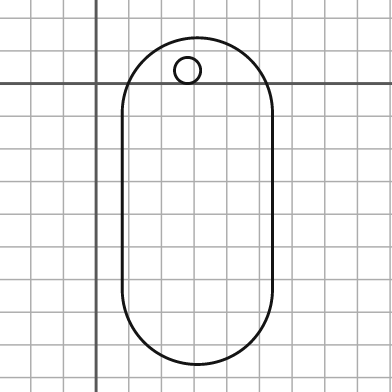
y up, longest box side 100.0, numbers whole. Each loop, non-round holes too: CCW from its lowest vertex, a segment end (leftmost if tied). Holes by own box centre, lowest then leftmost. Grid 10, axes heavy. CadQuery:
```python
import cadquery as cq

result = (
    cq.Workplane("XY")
    .moveTo(8.0, -63.0)
    .threePointArc((31.0, -86.0), (54.0, -63.0))
    .lineTo(54.0, -9.0)
    .threePointArc((31.0, 14.0), (8.0, -9.0))
    .close()
    .moveTo(28.0, 4.0)
    .circle(4.0)
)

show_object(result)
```